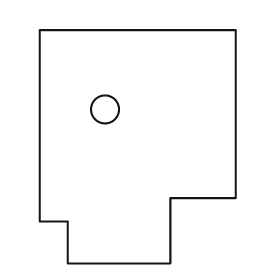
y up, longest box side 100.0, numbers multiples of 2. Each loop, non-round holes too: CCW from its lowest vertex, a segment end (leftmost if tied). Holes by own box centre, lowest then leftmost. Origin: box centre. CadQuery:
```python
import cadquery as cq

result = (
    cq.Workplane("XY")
    .moveTo(-30.0, -50.0)
    .lineTo(14.0, -50.0)
    .lineTo(14.0, -22.0)
    .lineTo(42.0, -22.0)
    .lineTo(42.0, 50.0)
    .lineTo(-42.0, 50.0)
    .lineTo(-42.0, -32.0)
    .lineTo(-30.0, -32.0)
    .close()
    .moveTo(-14.0, 16.0)
    .circle(6.0)
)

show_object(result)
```